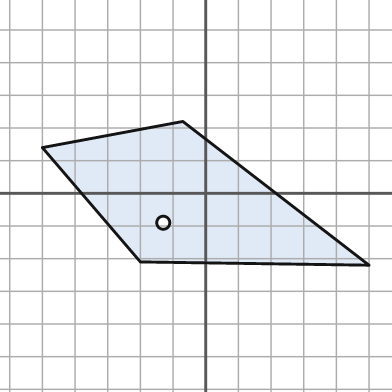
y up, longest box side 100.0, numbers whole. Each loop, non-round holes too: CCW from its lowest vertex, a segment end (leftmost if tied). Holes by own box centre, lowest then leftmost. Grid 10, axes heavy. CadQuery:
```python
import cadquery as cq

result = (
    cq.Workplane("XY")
    .moveTo(50.0, -22.0)
    .lineTo(-7.0, 22.0)
    .lineTo(-50.0, 14.0)
    .lineTo(-20.0, -21.0)
    .close()
    .moveTo(-13.0, -9.0)
    .circle(2.0)
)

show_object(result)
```